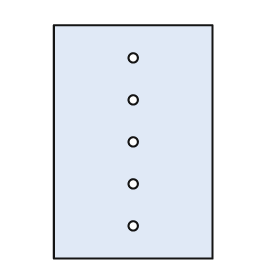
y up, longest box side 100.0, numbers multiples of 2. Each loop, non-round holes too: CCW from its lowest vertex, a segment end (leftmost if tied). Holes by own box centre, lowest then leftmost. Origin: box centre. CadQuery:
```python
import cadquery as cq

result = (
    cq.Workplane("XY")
    .moveTo(-34.0, -50.0)
    .lineTo(34.0, -50.0)
    .lineTo(34.0, 50.0)
    .lineTo(-34.0, 50.0)
    .close()
    .moveTo(0.0, -36.0)
    .circle(2.0)
    .moveTo(0.0, -18.0)
    .circle(2.0)
    .moveTo(0.0, 0.0)
    .circle(2.0)
    .moveTo(0.0, 18.0)
    .circle(2.0)
    .moveTo(0.0, 36.0)
    .circle(2.0)
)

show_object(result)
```